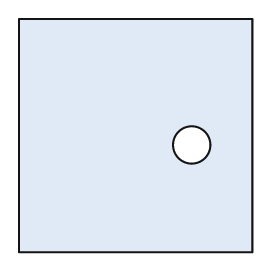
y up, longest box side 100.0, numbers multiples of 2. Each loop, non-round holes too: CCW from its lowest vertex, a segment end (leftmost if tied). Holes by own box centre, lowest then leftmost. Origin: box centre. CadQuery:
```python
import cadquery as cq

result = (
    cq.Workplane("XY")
    .moveTo(-50.0, -50.0)
    .lineTo(50.0, -50.0)
    .lineTo(50.0, 50.0)
    .lineTo(-50.0, 50.0)
    .close()
    .moveTo(24.0, -4.0)
    .circle(8.0)
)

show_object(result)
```